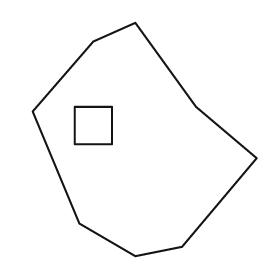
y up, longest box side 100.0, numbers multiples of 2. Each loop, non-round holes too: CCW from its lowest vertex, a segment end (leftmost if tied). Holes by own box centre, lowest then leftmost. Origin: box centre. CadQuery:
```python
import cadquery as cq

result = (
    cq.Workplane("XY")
    .moveTo(-4.0, -50.0)
    .lineTo(16.0, -46.0)
    .lineTo(48.0, -8.0)
    .lineTo(22.0, 14.0)
    .lineTo(-4.0, 50.0)
    .lineTo(-22.0, 42.0)
    .lineTo(-48.0, 12.0)
    .lineTo(-28.0, -36.0)
    .close()
    .moveTo(-30.0, -2.0)
    .lineTo(-14.0, -2.0)
    .lineTo(-14.0, 14.0)
    .lineTo(-30.0, 14.0)
    .close()
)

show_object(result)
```